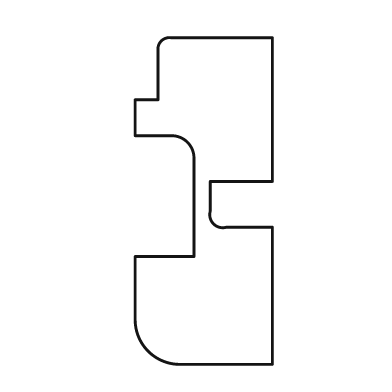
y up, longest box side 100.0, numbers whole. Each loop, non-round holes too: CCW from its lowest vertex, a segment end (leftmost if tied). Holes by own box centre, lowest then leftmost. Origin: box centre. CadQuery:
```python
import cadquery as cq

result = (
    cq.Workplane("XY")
    .moveTo(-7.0, -50.0)
    .lineTo(21.0, -50.0)
    .lineTo(21.0, -8.0)
    .lineTo(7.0, -8.0)
    .threePointArc((3.0, -7.0), (2.0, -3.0))
    .lineTo(2.0, 6.0)
    .lineTo(21.0, 6.0)
    .lineTo(21.0, 50.0)
    .lineTo(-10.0, 50.0)
    .threePointArc((-13.0, 49.0), (-14.0, 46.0))
    .lineTo(-14.0, 31.0)
    .lineTo(-21.0, 31.0)
    .lineTo(-21.0, 20.0)
    .lineTo(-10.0, 20.0)
    .threePointArc((-5.0, 18.0), (-3.0, 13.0))
    .lineTo(-3.0, -17.0)
    .lineTo(-21.0, -17.0)
    .lineTo(-21.0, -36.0)
    .threePointArc((-17.0, -46.0), (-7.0, -50.0))
    .close()
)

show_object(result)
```